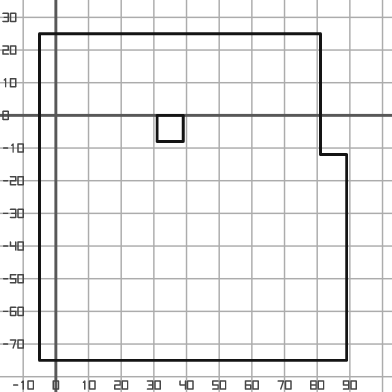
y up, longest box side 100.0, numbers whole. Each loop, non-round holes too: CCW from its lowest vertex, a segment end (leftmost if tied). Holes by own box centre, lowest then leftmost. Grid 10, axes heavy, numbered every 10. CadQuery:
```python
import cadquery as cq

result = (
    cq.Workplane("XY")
    .moveTo(-5.0, -75.0)
    .lineTo(89.0, -75.0)
    .lineTo(89.0, -12.0)
    .lineTo(81.0, -12.0)
    .lineTo(81.0, 25.0)
    .lineTo(-5.0, 25.0)
    .close()
    .moveTo(31.0, -8.0)
    .lineTo(39.0, -8.0)
    .lineTo(39.0, 0.0)
    .lineTo(31.0, 0.0)
    .close()
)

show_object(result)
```